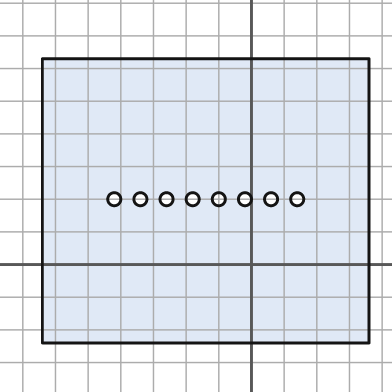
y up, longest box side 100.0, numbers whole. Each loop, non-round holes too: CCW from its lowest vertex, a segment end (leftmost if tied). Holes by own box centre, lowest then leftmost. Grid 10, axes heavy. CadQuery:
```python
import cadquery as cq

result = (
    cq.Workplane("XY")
    .moveTo(-64.0, -24.0)
    .lineTo(36.0, -24.0)
    .lineTo(36.0, 63.0)
    .lineTo(-64.0, 63.0)
    .close()
    .moveTo(-42.0, 20.0)
    .circle(2.0)
    .moveTo(-34.0, 20.0)
    .circle(2.0)
    .moveTo(-26.0, 20.0)
    .circle(2.0)
    .moveTo(-18.0, 20.0)
    .circle(2.0)
    .moveTo(-10.0, 20.0)
    .circle(2.0)
    .moveTo(-2.0, 20.0)
    .circle(2.0)
    .moveTo(6.0, 20.0)
    .circle(2.0)
    .moveTo(14.0, 20.0)
    .circle(2.0)
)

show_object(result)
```